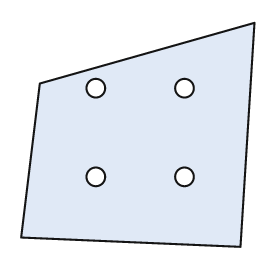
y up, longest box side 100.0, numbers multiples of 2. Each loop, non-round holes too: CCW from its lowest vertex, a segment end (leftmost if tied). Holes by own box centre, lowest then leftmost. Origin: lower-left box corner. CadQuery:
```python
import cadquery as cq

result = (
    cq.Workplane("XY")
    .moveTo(94.0, 0.0)
    .lineTo(100.0, 96.0)
    .lineTo(8.0, 70.0)
    .lineTo(0.0, 4.0)
    .close()
    .moveTo(32.0, 30.0)
    .circle(4.0)
    .moveTo(70.0, 30.0)
    .circle(4.0)
    .moveTo(32.0, 68.0)
    .circle(4.0)
    .moveTo(70.0, 68.0)
    .circle(4.0)
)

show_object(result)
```